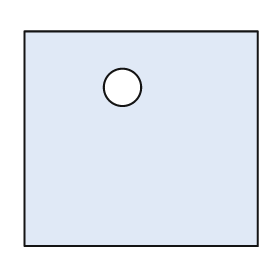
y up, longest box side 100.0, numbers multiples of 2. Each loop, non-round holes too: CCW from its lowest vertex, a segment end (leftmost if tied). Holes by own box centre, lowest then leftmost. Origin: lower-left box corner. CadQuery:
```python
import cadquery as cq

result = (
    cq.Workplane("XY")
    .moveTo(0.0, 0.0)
    .lineTo(100.0, 0.0)
    .lineTo(100.0, 92.0)
    .lineTo(0.0, 92.0)
    .close()
    .moveTo(42.0, 68.0)
    .circle(8.0)
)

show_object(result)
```